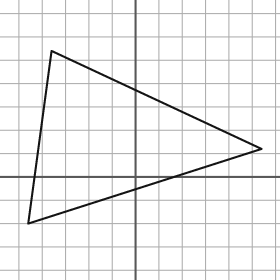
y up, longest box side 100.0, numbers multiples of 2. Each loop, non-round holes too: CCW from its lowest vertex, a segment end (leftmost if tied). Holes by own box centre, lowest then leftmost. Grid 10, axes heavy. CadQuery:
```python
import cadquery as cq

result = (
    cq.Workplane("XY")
    .moveTo(-46.0, -20.0)
    .lineTo(54.0, 12.0)
    .lineTo(-36.0, 54.0)
    .close()
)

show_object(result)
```